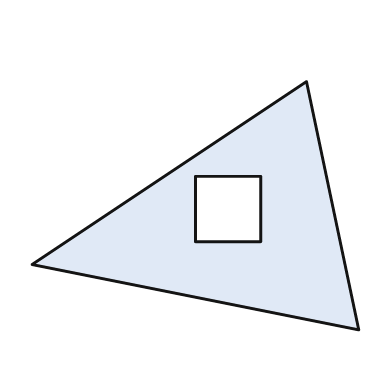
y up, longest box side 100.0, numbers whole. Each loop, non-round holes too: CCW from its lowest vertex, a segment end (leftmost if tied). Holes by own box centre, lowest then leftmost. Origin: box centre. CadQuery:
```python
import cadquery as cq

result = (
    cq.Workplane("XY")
    .moveTo(50.0, -38.0)
    .lineTo(34.0, 38.0)
    .lineTo(-50.0, -18.0)
    .close()
    .moveTo(0.0, -11.0)
    .lineTo(20.0, -11.0)
    .lineTo(20.0, 9.0)
    .lineTo(0.0, 9.0)
    .close()
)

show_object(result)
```